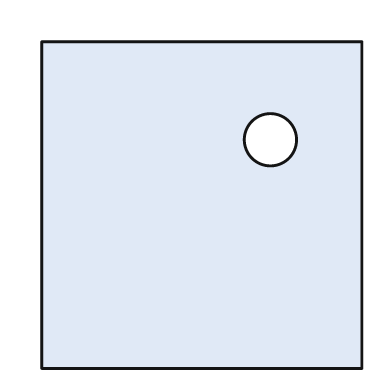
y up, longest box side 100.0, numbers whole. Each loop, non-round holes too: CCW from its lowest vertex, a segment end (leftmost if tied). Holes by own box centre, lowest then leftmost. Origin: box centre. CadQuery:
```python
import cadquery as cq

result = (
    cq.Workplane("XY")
    .moveTo(-49.0, -50.0)
    .lineTo(49.0, -50.0)
    .lineTo(49.0, 50.0)
    .lineTo(-49.0, 50.0)
    .close()
    .moveTo(21.0, 20.0)
    .circle(8.0)
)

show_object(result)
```